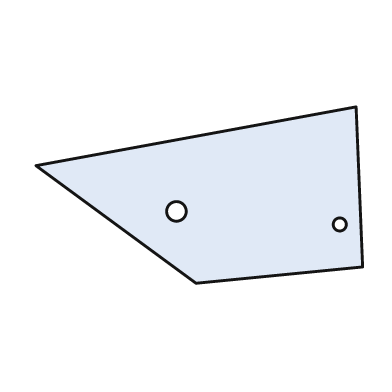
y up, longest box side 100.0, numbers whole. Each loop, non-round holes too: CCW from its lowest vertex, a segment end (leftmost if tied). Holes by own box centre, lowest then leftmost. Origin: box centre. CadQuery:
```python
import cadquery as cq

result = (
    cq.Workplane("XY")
    .moveTo(-1.0, -27.0)
    .lineTo(50.0, -22.0)
    .lineTo(48.0, 27.0)
    .lineTo(-50.0, 9.0)
    .close()
    .moveTo(43.0, -9.0)
    .circle(2.0)
    .moveTo(-7.0, -5.0)
    .circle(3.0)
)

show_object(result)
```